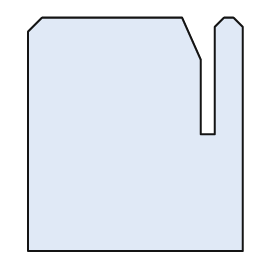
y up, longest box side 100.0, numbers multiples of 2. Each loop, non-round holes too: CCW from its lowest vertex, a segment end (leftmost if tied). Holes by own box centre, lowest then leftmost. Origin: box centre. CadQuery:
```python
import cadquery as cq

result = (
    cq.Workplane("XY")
    .moveTo(-46.0, -50.0)
    .lineTo(46.0, -50.0)
    .lineTo(46.0, 46.0)
    .lineTo(42.0, 50.0)
    .lineTo(38.0, 50.0)
    .lineTo(34.0, 46.0)
    .lineTo(34.0, 0.0)
    .lineTo(28.0, 0.0)
    .lineTo(28.0, 32.0)
    .lineTo(20.0, 50.0)
    .lineTo(-40.0, 50.0)
    .lineTo(-46.0, 44.0)
    .close()
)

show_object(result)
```